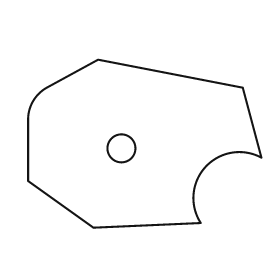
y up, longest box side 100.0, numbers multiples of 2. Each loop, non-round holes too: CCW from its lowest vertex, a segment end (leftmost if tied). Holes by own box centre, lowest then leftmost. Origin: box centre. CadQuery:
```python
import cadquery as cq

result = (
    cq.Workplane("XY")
    .moveTo(-22.0, -36.0)
    .lineTo(24.0, -34.0)
    .threePointArc((26.0, -10.0), (50.0, -6.0))
    .lineTo(42.0, 24.0)
    .lineTo(-20.0, 36.0)
    .lineTo(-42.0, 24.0)
    .threePointArc((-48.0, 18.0), (-50.0, 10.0))
    .lineTo(-50.0, -16.0)
    .close()
    .moveTo(-10.0, -2.0)
    .circle(6.0)
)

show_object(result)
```